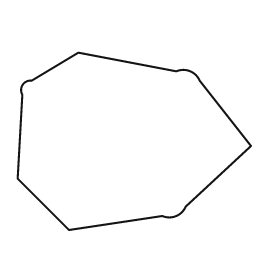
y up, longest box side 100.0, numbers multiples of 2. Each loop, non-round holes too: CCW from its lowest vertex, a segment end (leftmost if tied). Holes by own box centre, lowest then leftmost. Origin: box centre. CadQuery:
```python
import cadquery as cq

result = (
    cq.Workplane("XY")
    .moveTo(-28.0, -38.0)
    .lineTo(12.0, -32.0)
    .threePointArc((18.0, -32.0), (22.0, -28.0))
    .lineTo(50.0, -2.0)
    .lineTo(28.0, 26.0)
    .threePointArc((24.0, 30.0), (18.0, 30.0))
    .lineTo(-24.0, 38.0)
    .lineTo(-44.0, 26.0)
    .threePointArc((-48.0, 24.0), (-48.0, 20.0))
    .lineTo(-50.0, -16.0)
    .close()
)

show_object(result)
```